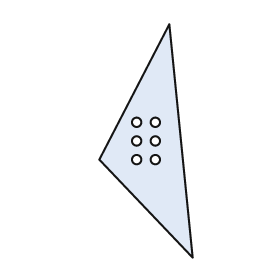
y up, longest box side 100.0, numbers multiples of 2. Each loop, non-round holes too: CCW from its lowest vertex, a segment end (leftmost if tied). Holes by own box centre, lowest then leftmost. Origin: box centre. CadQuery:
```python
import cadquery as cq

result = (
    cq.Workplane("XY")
    .moveTo(20.0, -50.0)
    .lineTo(10.0, 50.0)
    .lineTo(-20.0, -8.0)
    .close()
    .moveTo(-4.0, -8.0)
    .circle(2.0)
    .moveTo(4.0, -8.0)
    .circle(2.0)
    .moveTo(-4.0, 0.0)
    .circle(2.0)
    .moveTo(4.0, 0.0)
    .circle(2.0)
    .moveTo(-4.0, 8.0)
    .circle(2.0)
    .moveTo(4.0, 8.0)
    .circle(2.0)
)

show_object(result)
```